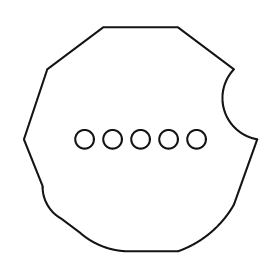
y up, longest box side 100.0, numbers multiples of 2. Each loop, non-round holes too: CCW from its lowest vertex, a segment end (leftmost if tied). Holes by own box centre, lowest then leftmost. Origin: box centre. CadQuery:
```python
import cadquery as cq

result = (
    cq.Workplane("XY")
    .moveTo(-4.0, -48.0)
    .lineTo(16.0, -48.0)
    .threePointArc((30.0, -40.0), (40.0, -28.0))
    .lineTo(50.0, 0.0)
    .threePointArc((36.0, 12.0), (40.0, 30.0))
    .lineTo(16.0, 48.0)
    .lineTo(-16.0, 48.0)
    .lineTo(-40.0, 30.0)
    .lineTo(-50.0, 0.0)
    .lineTo(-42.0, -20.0)
    .threePointArc((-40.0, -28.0), (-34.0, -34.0))
    .lineTo(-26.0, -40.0)
    .threePointArc((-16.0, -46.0), (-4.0, -48.0))
    .close()
    .moveTo(-24.0, 0.0)
    .circle(4.0)
    .moveTo(-12.0, 0.0)
    .circle(4.0)
    .moveTo(0.0, 0.0)
    .circle(4.0)
    .moveTo(12.0, 0.0)
    .circle(4.0)
    .moveTo(24.0, 0.0)
    .circle(4.0)
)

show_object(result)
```